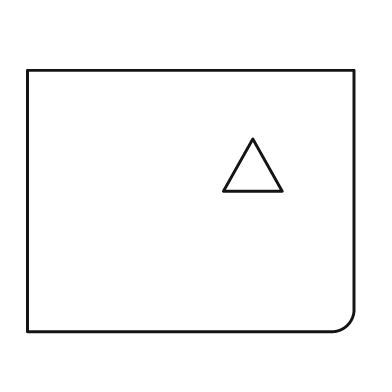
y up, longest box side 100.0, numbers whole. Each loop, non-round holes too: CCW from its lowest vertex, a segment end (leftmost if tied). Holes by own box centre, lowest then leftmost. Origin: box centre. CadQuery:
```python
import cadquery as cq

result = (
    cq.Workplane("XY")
    .moveTo(-50.0, -40.0)
    .lineTo(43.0, -40.0)
    .threePointArc((48.0, -38.0), (50.0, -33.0))
    .lineTo(50.0, 40.0)
    .lineTo(-50.0, 40.0)
    .close()
    .moveTo(10.0, 3.0)
    .lineTo(28.0, 3.0)
    .lineTo(19.0, 19.0)
    .close()
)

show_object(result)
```